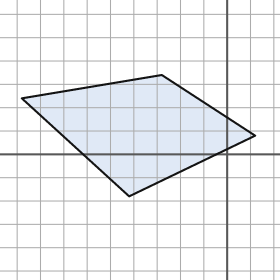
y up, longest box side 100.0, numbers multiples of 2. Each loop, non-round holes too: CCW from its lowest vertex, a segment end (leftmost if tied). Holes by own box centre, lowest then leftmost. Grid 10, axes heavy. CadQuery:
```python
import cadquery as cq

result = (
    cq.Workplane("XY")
    .moveTo(-42.0, -18.0)
    .lineTo(12.0, 8.0)
    .lineTo(-28.0, 34.0)
    .lineTo(-88.0, 24.0)
    .close()
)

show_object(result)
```